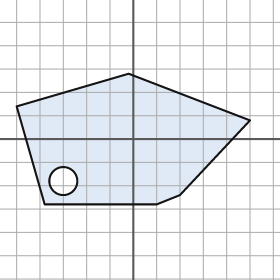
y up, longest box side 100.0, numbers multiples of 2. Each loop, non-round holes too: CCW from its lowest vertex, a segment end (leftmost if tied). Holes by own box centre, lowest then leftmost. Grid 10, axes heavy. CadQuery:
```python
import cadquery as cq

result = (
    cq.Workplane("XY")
    .moveTo(-38.0, -28.0)
    .lineTo(10.0, -28.0)
    .lineTo(20.0, -24.0)
    .lineTo(50.0, 8.0)
    .lineTo(-2.0, 28.0)
    .lineTo(-50.0, 14.0)
    .close()
    .moveTo(-30.0, -18.0)
    .circle(6.0)
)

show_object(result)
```